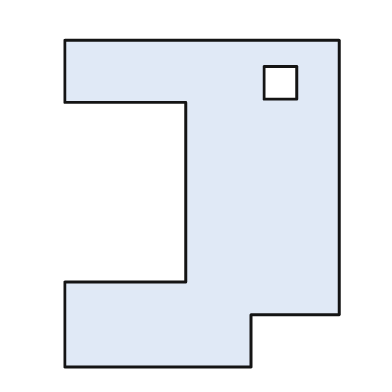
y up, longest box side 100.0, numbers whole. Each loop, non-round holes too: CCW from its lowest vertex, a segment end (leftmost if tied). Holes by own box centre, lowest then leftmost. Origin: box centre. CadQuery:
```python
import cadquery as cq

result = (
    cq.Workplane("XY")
    .moveTo(-42.0, -50.0)
    .lineTo(15.0, -50.0)
    .lineTo(15.0, -34.0)
    .lineTo(42.0, -34.0)
    .lineTo(42.0, 50.0)
    .lineTo(-42.0, 50.0)
    .lineTo(-42.0, 31.0)
    .lineTo(-5.0, 31.0)
    .lineTo(-5.0, -24.0)
    .lineTo(-42.0, -24.0)
    .close()
    .moveTo(19.0, 32.0)
    .lineTo(29.0, 32.0)
    .lineTo(29.0, 42.0)
    .lineTo(19.0, 42.0)
    .close()
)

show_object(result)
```